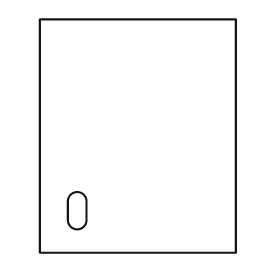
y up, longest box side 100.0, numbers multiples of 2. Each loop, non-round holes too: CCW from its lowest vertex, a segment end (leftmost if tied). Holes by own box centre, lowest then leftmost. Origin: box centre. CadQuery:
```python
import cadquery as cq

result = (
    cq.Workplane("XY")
    .moveTo(-42.0, -50.0)
    .lineTo(42.0, -50.0)
    .lineTo(42.0, 50.0)
    .lineTo(-42.0, 50.0)
    .close()
    .moveTo(-30.0, -36.0)
    .threePointArc((-26.0, -40.0), (-22.0, -36.0))
    .lineTo(-22.0, -28.0)
    .threePointArc((-26.0, -24.0), (-30.0, -28.0))
    .close()
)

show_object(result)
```